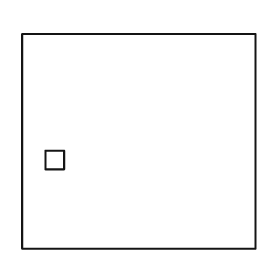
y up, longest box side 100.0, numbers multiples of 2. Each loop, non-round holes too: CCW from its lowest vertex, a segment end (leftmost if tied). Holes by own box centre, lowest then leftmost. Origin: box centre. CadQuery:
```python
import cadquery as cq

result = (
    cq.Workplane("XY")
    .moveTo(-50.0, -46.0)
    .lineTo(50.0, -46.0)
    .lineTo(50.0, 46.0)
    .lineTo(-50.0, 46.0)
    .close()
    .moveTo(-40.0, -12.0)
    .lineTo(-32.0, -12.0)
    .lineTo(-32.0, -4.0)
    .lineTo(-40.0, -4.0)
    .close()
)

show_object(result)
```